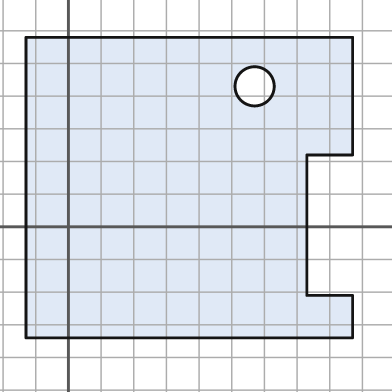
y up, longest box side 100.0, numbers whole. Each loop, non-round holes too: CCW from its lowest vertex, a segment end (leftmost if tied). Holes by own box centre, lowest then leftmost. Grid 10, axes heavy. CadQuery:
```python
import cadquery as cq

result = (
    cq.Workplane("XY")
    .moveTo(-13.0, -34.0)
    .lineTo(87.0, -34.0)
    .lineTo(87.0, -21.0)
    .lineTo(73.0, -21.0)
    .lineTo(73.0, 22.0)
    .lineTo(87.0, 22.0)
    .lineTo(87.0, 58.0)
    .lineTo(-13.0, 58.0)
    .close()
    .moveTo(57.0, 43.0)
    .circle(6.0)
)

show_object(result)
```